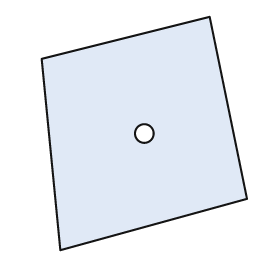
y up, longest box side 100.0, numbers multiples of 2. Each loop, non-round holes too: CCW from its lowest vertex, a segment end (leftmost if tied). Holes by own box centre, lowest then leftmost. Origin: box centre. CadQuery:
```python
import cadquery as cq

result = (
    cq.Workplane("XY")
    .moveTo(-36.0, -50.0)
    .lineTo(44.0, -28.0)
    .lineTo(28.0, 50.0)
    .lineTo(-44.0, 32.0)
    .close()
    .moveTo(0.0, 0.0)
    .circle(4.0)
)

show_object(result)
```